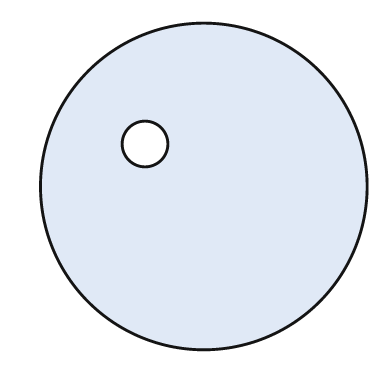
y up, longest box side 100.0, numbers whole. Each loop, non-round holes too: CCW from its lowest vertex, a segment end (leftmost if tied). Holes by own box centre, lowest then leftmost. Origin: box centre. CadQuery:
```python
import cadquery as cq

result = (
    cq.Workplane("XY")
    .moveTo(0.0, 0.0)
    .circle(50.0)
    .moveTo(-18.0, 13.0)
    .circle(7.0)
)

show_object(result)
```